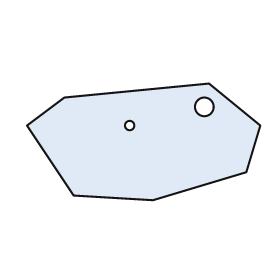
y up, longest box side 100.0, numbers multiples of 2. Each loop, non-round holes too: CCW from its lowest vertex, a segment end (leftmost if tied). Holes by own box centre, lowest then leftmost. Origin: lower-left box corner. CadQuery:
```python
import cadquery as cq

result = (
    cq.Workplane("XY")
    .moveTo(54.0, 0.0)
    .lineTo(94.0, 12.0)
    .lineTo(100.0, 32.0)
    .lineTo(78.0, 50.0)
    .lineTo(16.0, 44.0)
    .lineTo(0.0, 32.0)
    .lineTo(20.0, 2.0)
    .close()
    .moveTo(44.0, 32.0)
    .circle(2.0)
    .moveTo(76.0, 40.0)
    .circle(4.0)
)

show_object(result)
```